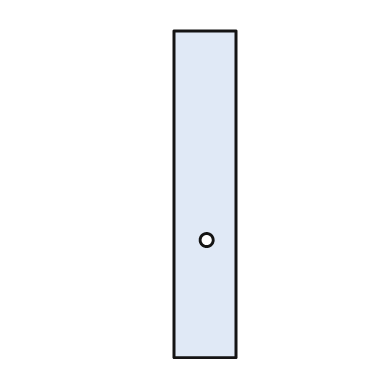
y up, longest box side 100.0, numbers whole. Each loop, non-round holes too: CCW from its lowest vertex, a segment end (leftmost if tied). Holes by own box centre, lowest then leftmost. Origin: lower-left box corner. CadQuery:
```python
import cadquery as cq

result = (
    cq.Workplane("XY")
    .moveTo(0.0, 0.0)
    .lineTo(19.0, 0.0)
    .lineTo(19.0, 100.0)
    .lineTo(0.0, 100.0)
    .close()
    .moveTo(10.0, 36.0)
    .circle(2.0)
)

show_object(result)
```